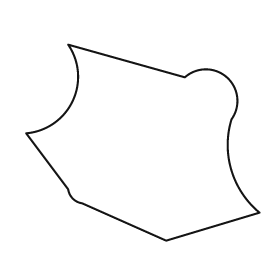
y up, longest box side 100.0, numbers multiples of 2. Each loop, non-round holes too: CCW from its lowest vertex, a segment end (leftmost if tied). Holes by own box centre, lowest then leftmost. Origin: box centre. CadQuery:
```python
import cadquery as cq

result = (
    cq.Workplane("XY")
    .moveTo(10.0, -42.0)
    .lineTo(50.0, -30.0)
    .threePointArc((38.0, -12.0), (38.0, 10.0))
    .threePointArc((36.0, 28.0), (18.0, 28.0))
    .lineTo(-32.0, 42.0)
    .threePointArc((-30.0, 18.0), (-50.0, 4.0))
    .lineTo(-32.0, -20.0)
    .threePointArc((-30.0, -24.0), (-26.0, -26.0))
    .close()
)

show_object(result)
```